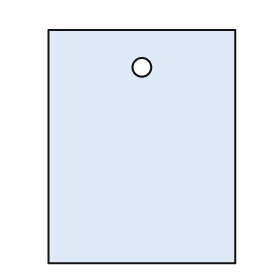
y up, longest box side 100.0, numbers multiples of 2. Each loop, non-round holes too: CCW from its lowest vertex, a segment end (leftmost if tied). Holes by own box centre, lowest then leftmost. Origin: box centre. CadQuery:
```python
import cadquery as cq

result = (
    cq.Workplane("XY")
    .moveTo(-40.0, -50.0)
    .lineTo(40.0, -50.0)
    .lineTo(40.0, 50.0)
    .lineTo(-40.0, 50.0)
    .close()
    .moveTo(0.0, 34.0)
    .circle(4.0)
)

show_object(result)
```